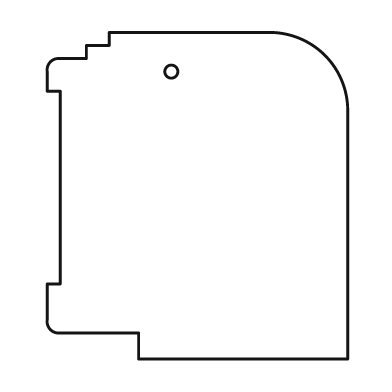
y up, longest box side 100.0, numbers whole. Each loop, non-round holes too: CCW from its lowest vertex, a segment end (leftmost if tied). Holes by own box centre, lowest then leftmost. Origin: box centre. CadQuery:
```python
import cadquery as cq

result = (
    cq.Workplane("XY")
    .moveTo(-18.0, -50.0)
    .lineTo(46.0, -50.0)
    .lineTo(46.0, 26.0)
    .threePointArc((39.0, 43.0), (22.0, 50.0))
    .lineTo(-27.0, 50.0)
    .lineTo(-27.0, 46.0)
    .lineTo(-34.0, 46.0)
    .lineTo(-34.0, 42.0)
    .lineTo(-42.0, 42.0)
    .threePointArc((-45.0, 41.0), (-46.0, 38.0))
    .lineTo(-46.0, 32.0)
    .lineTo(-42.0, 32.0)
    .lineTo(-42.0, -27.0)
    .lineTo(-46.0, -27.0)
    .lineTo(-46.0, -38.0)
    .threePointArc((-45.0, -41.0), (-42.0, -42.0))
    .lineTo(-18.0, -42.0)
    .close()
    .moveTo(-8.0, 38.0)
    .circle(2.0)
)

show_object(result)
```